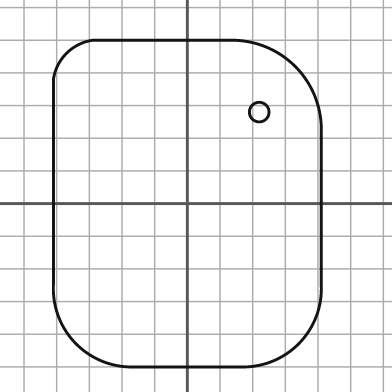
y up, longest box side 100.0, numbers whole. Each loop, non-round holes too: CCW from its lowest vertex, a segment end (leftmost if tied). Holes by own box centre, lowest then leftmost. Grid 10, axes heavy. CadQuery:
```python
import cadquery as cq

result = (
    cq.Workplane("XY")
    .moveTo(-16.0, -50.0)
    .lineTo(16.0, -50.0)
    .threePointArc((34.0, -43.0), (41.0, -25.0))
    .lineTo(41.0, 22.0)
    .threePointArc((33.0, 42.0), (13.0, 50.0))
    .lineTo(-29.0, 50.0)
    .threePointArc((-37.0, 46.0), (-41.0, 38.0))
    .lineTo(-41.0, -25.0)
    .threePointArc((-34.0, -43.0), (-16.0, -50.0))
    .close()
    .moveTo(22.0, 28.0)
    .circle(3.0)
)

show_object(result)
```